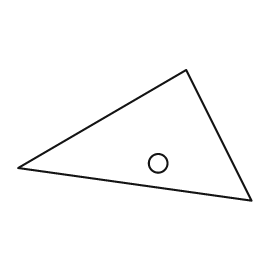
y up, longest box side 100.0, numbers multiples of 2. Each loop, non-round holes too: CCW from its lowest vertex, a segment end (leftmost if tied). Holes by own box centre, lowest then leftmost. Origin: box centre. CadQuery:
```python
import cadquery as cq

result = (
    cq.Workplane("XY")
    .moveTo(50.0, -28.0)
    .lineTo(22.0, 28.0)
    .lineTo(-50.0, -14.0)
    .close()
    .moveTo(10.0, -12.0)
    .circle(4.0)
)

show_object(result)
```